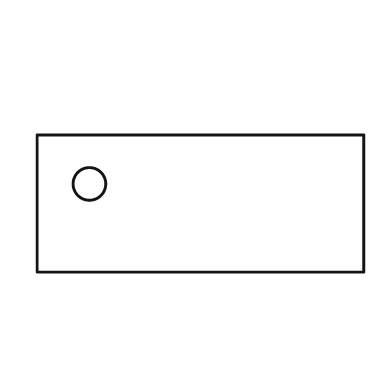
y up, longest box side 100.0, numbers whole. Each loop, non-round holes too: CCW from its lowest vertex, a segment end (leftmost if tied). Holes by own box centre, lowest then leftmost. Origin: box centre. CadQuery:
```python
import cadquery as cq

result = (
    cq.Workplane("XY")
    .moveTo(-50.0, -21.0)
    .lineTo(50.0, -21.0)
    .lineTo(50.0, 21.0)
    .lineTo(-50.0, 21.0)
    .close()
    .moveTo(-34.0, 6.0)
    .circle(5.0)
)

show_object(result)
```